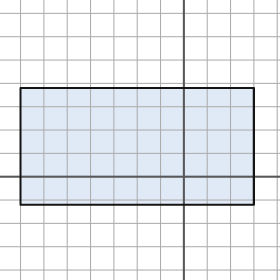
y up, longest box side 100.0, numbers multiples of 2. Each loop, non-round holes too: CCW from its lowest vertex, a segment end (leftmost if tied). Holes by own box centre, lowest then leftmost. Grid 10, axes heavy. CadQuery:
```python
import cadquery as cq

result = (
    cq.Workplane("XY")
    .moveTo(-70.0, -12.0)
    .lineTo(30.0, -12.0)
    .lineTo(30.0, 38.0)
    .lineTo(-70.0, 38.0)
    .close()
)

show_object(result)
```